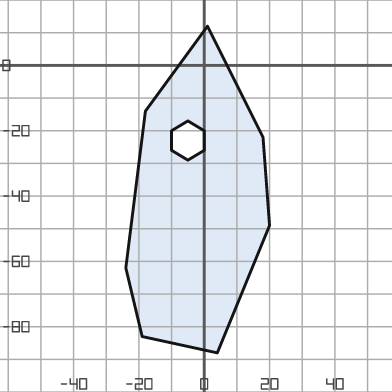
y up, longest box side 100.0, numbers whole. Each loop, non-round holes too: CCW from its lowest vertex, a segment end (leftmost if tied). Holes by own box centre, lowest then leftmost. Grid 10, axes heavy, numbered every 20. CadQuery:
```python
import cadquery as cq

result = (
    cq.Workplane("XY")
    .moveTo(4.0, -88.0)
    .lineTo(20.0, -49.0)
    .lineTo(18.0, -22.0)
    .lineTo(1.0, 12.0)
    .lineTo(-18.0, -14.0)
    .lineTo(-24.0, -62.0)
    .lineTo(-19.0, -83.0)
    .close()
    .moveTo(-5.0, -29.0)
    .lineTo(0.0, -26.0)
    .lineTo(0.0, -20.0)
    .lineTo(-5.0, -17.0)
    .lineTo(-10.0, -20.0)
    .lineTo(-10.0, -26.0)
    .close()
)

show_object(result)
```